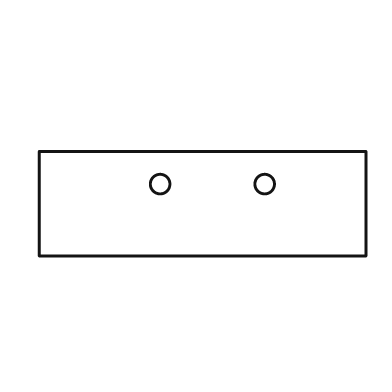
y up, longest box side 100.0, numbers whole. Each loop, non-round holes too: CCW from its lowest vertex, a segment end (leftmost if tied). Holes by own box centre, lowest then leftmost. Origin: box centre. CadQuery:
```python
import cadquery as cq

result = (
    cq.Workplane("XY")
    .moveTo(-50.0, -16.0)
    .lineTo(50.0, -16.0)
    .lineTo(50.0, 16.0)
    .lineTo(-50.0, 16.0)
    .close()
    .moveTo(-13.0, 6.0)
    .circle(3.0)
    .moveTo(19.0, 6.0)
    .circle(3.0)
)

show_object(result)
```